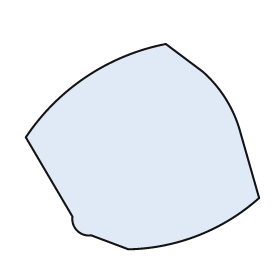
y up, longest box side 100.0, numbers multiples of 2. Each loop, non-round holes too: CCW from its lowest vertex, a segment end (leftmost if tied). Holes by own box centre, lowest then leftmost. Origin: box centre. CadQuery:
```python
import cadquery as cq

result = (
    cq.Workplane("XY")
    .moveTo(-6.0, -44.0)
    .threePointArc((24.0, -38.0), (50.0, -22.0))
    .lineTo(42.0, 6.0)
    .threePointArc((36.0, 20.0), (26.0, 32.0))
    .lineTo(10.0, 44.0)
    .threePointArc((-24.0, 30.0), (-50.0, 4.0))
    .lineTo(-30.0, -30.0)
    .threePointArc((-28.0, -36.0), (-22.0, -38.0))
    .close()
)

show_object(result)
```